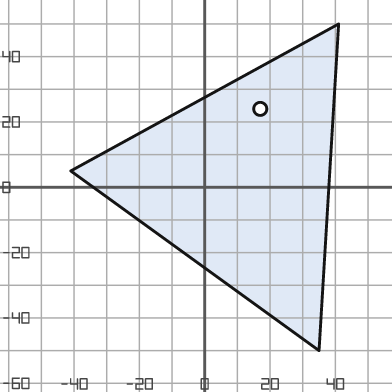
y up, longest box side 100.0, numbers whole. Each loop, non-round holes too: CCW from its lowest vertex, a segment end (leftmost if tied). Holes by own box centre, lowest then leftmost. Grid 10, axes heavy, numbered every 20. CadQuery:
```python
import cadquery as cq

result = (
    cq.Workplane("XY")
    .moveTo(35.0, -50.0)
    .lineTo(41.0, 50.0)
    .lineTo(-41.0, 5.0)
    .close()
    .moveTo(17.0, 24.0)
    .circle(2.0)
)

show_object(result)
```